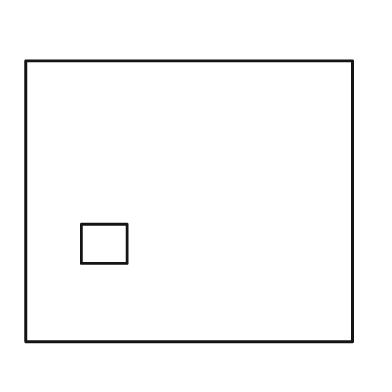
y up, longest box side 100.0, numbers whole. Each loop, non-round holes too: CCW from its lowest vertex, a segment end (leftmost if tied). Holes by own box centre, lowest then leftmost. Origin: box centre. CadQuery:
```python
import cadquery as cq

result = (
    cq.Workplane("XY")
    .moveTo(-50.0, -43.0)
    .lineTo(50.0, -43.0)
    .lineTo(50.0, 43.0)
    .lineTo(-50.0, 43.0)
    .close()
    .moveTo(-33.0, -19.0)
    .lineTo(-19.0, -19.0)
    .lineTo(-19.0, -7.0)
    .lineTo(-33.0, -7.0)
    .close()
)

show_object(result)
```